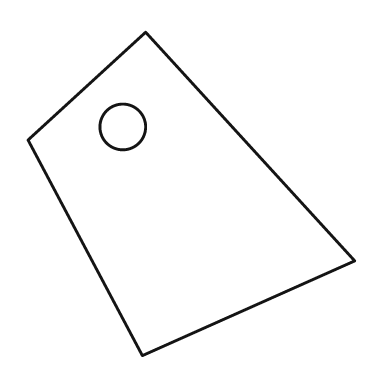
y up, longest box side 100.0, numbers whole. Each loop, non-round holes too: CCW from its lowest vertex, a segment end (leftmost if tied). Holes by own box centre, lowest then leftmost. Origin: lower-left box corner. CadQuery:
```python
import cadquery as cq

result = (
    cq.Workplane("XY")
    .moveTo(35.0, 0.0)
    .lineTo(100.0, 29.0)
    .lineTo(36.0, 99.0)
    .lineTo(0.0, 66.0)
    .close()
    .moveTo(29.0, 70.0)
    .circle(7.0)
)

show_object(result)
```